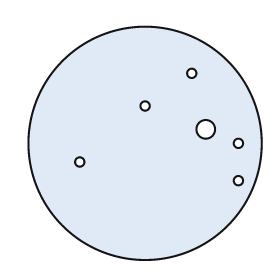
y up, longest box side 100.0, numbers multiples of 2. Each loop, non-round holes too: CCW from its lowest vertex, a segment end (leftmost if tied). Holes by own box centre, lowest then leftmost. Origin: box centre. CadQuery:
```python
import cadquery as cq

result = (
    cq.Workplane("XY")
    .moveTo(0.0, 0.0)
    .circle(50.0)
    .moveTo(40.0, -16.0)
    .circle(2.0)
    .moveTo(-28.0, -8.0)
    .circle(2.0)
    .moveTo(40.0, 0.0)
    .circle(2.0)
    .moveTo(26.0, 6.0)
    .circle(4.0)
    .moveTo(0.0, 16.0)
    .circle(2.0)
    .moveTo(20.0, 30.0)
    .circle(2.0)
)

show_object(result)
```